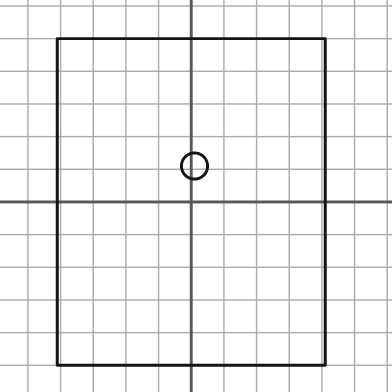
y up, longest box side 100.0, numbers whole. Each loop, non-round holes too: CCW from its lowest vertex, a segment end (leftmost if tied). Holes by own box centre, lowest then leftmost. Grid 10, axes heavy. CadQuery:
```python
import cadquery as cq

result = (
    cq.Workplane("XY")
    .moveTo(-41.0, -50.0)
    .lineTo(41.0, -50.0)
    .lineTo(41.0, 50.0)
    .lineTo(-41.0, 50.0)
    .close()
    .moveTo(1.0, 11.0)
    .circle(4.0)
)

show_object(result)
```